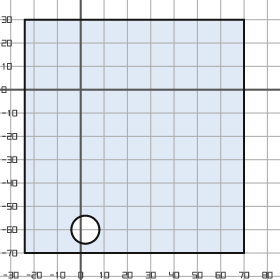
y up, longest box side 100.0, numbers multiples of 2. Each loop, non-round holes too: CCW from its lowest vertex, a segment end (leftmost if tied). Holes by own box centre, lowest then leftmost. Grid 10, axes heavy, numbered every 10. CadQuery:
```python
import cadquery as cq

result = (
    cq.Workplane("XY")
    .moveTo(-24.0, -70.0)
    .lineTo(70.0, -70.0)
    .lineTo(70.0, 30.0)
    .lineTo(-24.0, 30.0)
    .close()
    .moveTo(2.0, -60.0)
    .circle(6.0)
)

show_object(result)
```